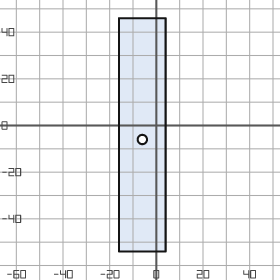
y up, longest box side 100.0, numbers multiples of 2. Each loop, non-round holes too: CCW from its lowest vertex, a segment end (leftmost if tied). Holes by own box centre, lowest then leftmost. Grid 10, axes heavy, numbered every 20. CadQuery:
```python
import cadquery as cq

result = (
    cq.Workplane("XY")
    .moveTo(-16.0, -54.0)
    .lineTo(4.0, -54.0)
    .lineTo(4.0, 46.0)
    .lineTo(-16.0, 46.0)
    .close()
    .moveTo(-6.0, -6.0)
    .circle(2.0)
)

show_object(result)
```